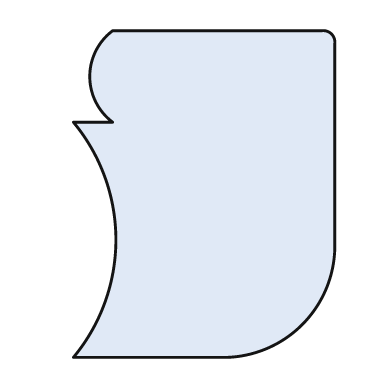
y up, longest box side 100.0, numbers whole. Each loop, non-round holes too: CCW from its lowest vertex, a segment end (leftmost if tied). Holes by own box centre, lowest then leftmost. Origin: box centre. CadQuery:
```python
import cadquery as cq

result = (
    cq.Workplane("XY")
    .moveTo(-40.0, -50.0)
    .lineTo(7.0, -50.0)
    .threePointArc((30.0, -40.0), (40.0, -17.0))
    .lineTo(40.0, 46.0)
    .threePointArc((39.0, 49.0), (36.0, 50.0))
    .lineTo(-28.0, 50.0)
    .threePointArc((-35.0, 36.0), (-28.0, 22.0))
    .lineTo(-40.0, 22.0)
    .threePointArc((-27.0, -14.0), (-40.0, -50.0))
    .close()
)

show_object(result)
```